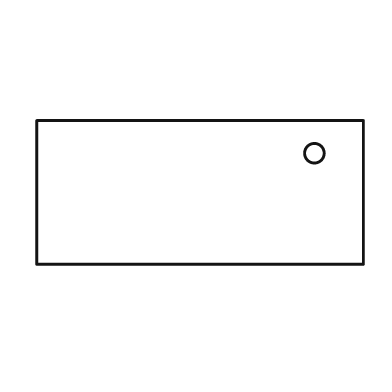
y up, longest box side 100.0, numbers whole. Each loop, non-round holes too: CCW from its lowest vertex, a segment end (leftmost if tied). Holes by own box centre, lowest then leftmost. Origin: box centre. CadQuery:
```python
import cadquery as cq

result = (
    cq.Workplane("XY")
    .moveTo(-50.0, -22.0)
    .lineTo(50.0, -22.0)
    .lineTo(50.0, 22.0)
    .lineTo(-50.0, 22.0)
    .close()
    .moveTo(35.0, 12.0)
    .circle(3.0)
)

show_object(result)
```